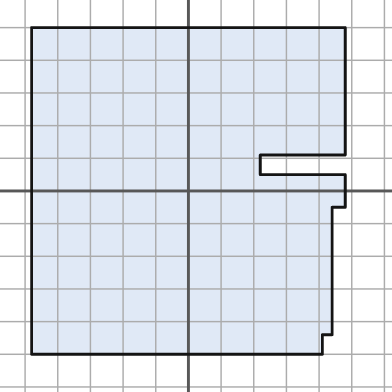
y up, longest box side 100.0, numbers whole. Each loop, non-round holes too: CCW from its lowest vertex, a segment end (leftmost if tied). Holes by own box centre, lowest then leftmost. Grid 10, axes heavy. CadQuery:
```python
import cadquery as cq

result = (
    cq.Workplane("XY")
    .moveTo(-48.0, -50.0)
    .lineTo(41.0, -50.0)
    .lineTo(41.0, -44.0)
    .lineTo(44.0, -44.0)
    .lineTo(44.0, -5.0)
    .lineTo(48.0, -5.0)
    .lineTo(48.0, 5.0)
    .lineTo(22.0, 5.0)
    .lineTo(22.0, 11.0)
    .lineTo(48.0, 11.0)
    .lineTo(48.0, 50.0)
    .lineTo(-48.0, 50.0)
    .close()
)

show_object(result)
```